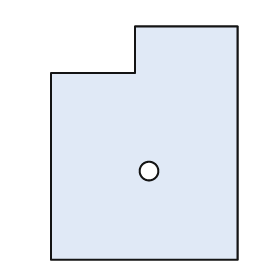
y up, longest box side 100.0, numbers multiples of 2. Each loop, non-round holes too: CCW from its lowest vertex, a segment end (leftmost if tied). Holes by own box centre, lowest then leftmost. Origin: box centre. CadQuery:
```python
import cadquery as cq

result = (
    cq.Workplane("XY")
    .moveTo(-40.0, -50.0)
    .lineTo(40.0, -50.0)
    .lineTo(40.0, 50.0)
    .lineTo(-4.0, 50.0)
    .lineTo(-4.0, 30.0)
    .lineTo(-40.0, 30.0)
    .close()
    .moveTo(2.0, -12.0)
    .circle(4.0)
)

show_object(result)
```